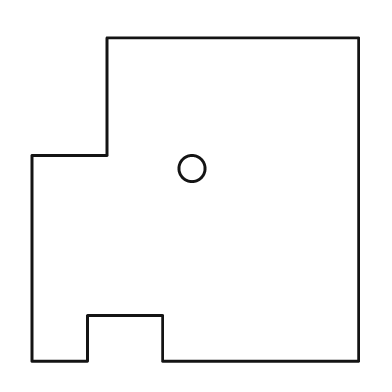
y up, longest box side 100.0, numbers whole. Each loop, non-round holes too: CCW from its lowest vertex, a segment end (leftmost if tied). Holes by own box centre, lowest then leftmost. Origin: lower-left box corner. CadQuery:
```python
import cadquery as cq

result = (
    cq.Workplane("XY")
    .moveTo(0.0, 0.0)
    .lineTo(17.0, 0.0)
    .lineTo(17.0, 14.0)
    .lineTo(40.0, 14.0)
    .lineTo(40.0, 0.0)
    .lineTo(100.0, 0.0)
    .lineTo(100.0, 99.0)
    .lineTo(23.0, 99.0)
    .lineTo(23.0, 63.0)
    .lineTo(0.0, 63.0)
    .close()
    .moveTo(49.0, 59.0)
    .circle(4.0)
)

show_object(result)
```